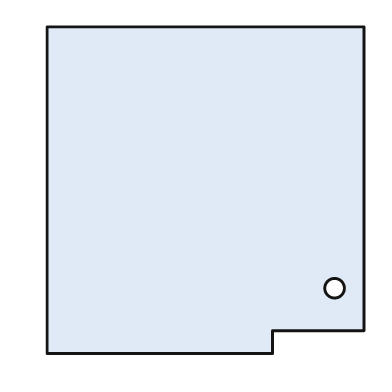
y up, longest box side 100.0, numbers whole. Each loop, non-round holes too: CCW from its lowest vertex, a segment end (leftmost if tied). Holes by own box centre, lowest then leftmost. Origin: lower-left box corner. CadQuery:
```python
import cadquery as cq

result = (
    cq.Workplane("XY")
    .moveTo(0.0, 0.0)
    .lineTo(69.0, 0.0)
    .lineTo(69.0, 7.0)
    .lineTo(97.0, 7.0)
    .lineTo(97.0, 100.0)
    .lineTo(0.0, 100.0)
    .close()
    .moveTo(88.0, 20.0)
    .circle(3.0)
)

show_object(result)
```